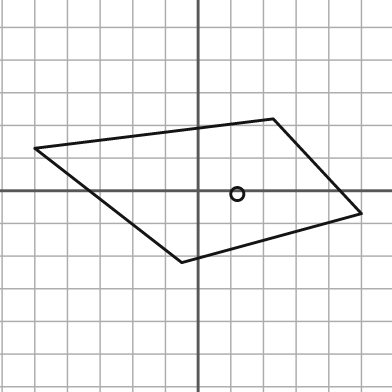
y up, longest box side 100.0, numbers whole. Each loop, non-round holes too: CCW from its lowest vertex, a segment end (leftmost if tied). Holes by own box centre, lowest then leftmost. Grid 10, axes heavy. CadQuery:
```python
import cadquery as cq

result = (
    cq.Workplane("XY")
    .moveTo(-5.0, -22.0)
    .lineTo(50.0, -7.0)
    .lineTo(23.0, 22.0)
    .lineTo(-50.0, 13.0)
    .close()
    .moveTo(12.0, -1.0)
    .circle(2.0)
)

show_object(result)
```